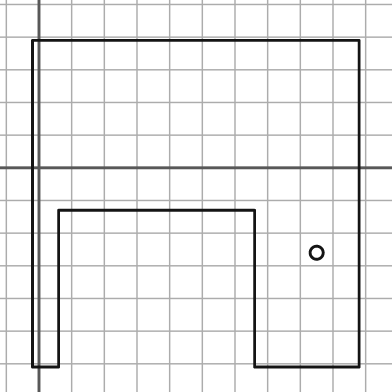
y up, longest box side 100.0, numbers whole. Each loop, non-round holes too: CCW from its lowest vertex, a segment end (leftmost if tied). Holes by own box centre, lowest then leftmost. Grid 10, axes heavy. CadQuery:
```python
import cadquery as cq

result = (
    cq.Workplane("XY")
    .moveTo(-2.0, -61.0)
    .lineTo(6.0, -61.0)
    .lineTo(6.0, -13.0)
    .lineTo(66.0, -13.0)
    .lineTo(66.0, -61.0)
    .lineTo(98.0, -61.0)
    .lineTo(98.0, 39.0)
    .lineTo(-2.0, 39.0)
    .close()
    .moveTo(85.0, -26.0)
    .circle(2.0)
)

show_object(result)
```